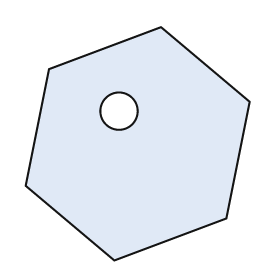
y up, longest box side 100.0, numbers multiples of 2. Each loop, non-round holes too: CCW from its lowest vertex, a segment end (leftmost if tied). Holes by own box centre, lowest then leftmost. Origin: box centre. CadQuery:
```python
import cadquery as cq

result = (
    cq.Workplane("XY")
    .moveTo(-10.0, -50.0)
    .lineTo(38.0, -32.0)
    .lineTo(48.0, 18.0)
    .lineTo(10.0, 50.0)
    .lineTo(-38.0, 32.0)
    .lineTo(-48.0, -18.0)
    .close()
    .moveTo(-8.0, 14.0)
    .circle(8.0)
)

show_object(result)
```